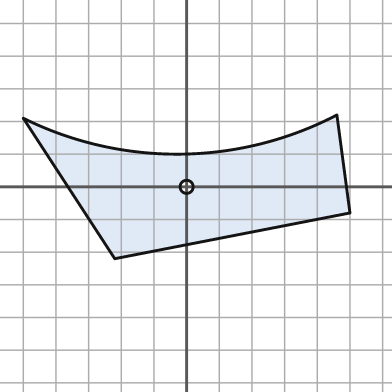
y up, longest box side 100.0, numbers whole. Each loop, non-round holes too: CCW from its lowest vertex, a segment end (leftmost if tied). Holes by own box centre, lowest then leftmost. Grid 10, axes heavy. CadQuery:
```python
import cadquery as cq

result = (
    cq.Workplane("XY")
    .moveTo(-22.0, -22.0)
    .lineTo(50.0, -8.0)
    .lineTo(46.0, 22.0)
    .threePointArc((-2.0, 10.0), (-50.0, 21.0))
    .close()
    .moveTo(0.0, 0.0)
    .circle(2.0)
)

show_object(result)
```